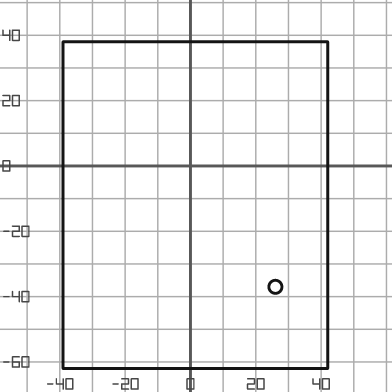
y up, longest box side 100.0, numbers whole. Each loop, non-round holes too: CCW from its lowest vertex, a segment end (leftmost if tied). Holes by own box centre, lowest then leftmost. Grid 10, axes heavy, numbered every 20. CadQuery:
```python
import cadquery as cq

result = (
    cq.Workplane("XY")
    .moveTo(-39.0, -62.0)
    .lineTo(42.0, -62.0)
    .lineTo(42.0, 38.0)
    .lineTo(-39.0, 38.0)
    .close()
    .moveTo(26.0, -37.0)
    .circle(2.0)
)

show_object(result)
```